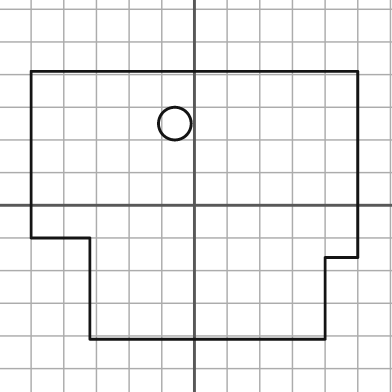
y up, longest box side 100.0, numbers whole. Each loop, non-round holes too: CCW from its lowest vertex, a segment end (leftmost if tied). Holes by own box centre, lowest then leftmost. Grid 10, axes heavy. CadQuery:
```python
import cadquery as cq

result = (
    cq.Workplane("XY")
    .moveTo(-32.0, -41.0)
    .lineTo(40.0, -41.0)
    .lineTo(40.0, -16.0)
    .lineTo(50.0, -16.0)
    .lineTo(50.0, 41.0)
    .lineTo(-50.0, 41.0)
    .lineTo(-50.0, -10.0)
    .lineTo(-32.0, -10.0)
    .close()
    .moveTo(-6.0, 25.0)
    .circle(5.0)
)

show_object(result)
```